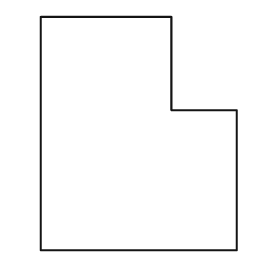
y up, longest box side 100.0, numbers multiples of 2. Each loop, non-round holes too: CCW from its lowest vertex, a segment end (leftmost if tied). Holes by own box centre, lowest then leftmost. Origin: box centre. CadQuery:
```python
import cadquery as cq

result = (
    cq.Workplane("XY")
    .moveTo(-42.0, -50.0)
    .lineTo(42.0, -50.0)
    .lineTo(42.0, 10.0)
    .lineTo(14.0, 10.0)
    .lineTo(14.0, 50.0)
    .lineTo(-42.0, 50.0)
    .close()
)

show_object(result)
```